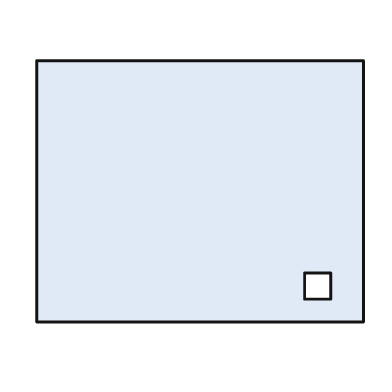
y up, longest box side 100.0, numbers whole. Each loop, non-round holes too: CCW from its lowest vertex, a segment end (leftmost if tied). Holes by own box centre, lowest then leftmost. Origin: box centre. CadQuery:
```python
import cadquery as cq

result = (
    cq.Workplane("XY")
    .moveTo(-50.0, -40.0)
    .lineTo(50.0, -40.0)
    .lineTo(50.0, 40.0)
    .lineTo(-50.0, 40.0)
    .close()
    .moveTo(32.0, -33.0)
    .lineTo(40.0, -33.0)
    .lineTo(40.0, -25.0)
    .lineTo(32.0, -25.0)
    .close()
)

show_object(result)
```